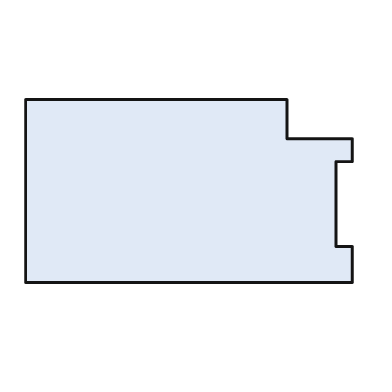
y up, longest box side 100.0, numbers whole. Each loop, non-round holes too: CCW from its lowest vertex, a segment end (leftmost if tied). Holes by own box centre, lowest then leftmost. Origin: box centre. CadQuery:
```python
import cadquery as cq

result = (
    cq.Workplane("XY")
    .moveTo(-50.0, -28.0)
    .lineTo(50.0, -28.0)
    .lineTo(50.0, -17.0)
    .lineTo(45.0, -17.0)
    .lineTo(45.0, 9.0)
    .lineTo(50.0, 9.0)
    .lineTo(50.0, 16.0)
    .lineTo(30.0, 16.0)
    .lineTo(30.0, 28.0)
    .lineTo(-50.0, 28.0)
    .close()
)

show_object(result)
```